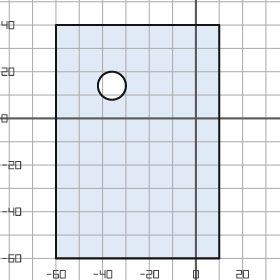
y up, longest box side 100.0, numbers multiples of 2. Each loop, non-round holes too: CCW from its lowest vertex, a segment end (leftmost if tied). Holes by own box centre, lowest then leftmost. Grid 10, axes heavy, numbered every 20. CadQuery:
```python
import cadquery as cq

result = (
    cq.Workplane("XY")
    .moveTo(-60.0, -60.0)
    .lineTo(10.0, -60.0)
    .lineTo(10.0, 40.0)
    .lineTo(-60.0, 40.0)
    .close()
    .moveTo(-36.0, 14.0)
    .circle(6.0)
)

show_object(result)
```